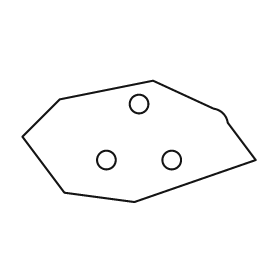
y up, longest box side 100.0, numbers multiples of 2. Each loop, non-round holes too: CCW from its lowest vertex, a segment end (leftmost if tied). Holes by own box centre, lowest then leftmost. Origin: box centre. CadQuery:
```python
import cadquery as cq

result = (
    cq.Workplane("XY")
    .moveTo(-2.0, -26.0)
    .lineTo(50.0, -8.0)
    .lineTo(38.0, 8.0)
    .threePointArc((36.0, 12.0), (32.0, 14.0))
    .lineTo(6.0, 26.0)
    .lineTo(-34.0, 18.0)
    .lineTo(-50.0, 2.0)
    .lineTo(-32.0, -22.0)
    .close()
    .moveTo(-14.0, -8.0)
    .circle(4.0)
    .moveTo(14.0, -8.0)
    .circle(4.0)
    .moveTo(0.0, 16.0)
    .circle(4.0)
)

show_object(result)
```